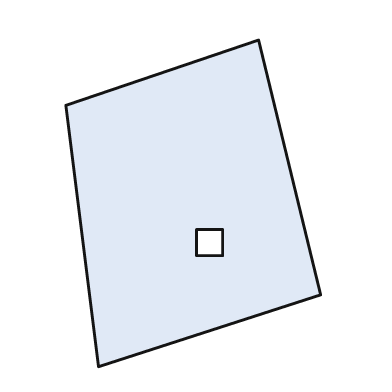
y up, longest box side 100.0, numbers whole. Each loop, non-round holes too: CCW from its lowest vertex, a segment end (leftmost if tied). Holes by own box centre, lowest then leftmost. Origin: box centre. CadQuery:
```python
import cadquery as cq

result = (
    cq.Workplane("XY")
    .moveTo(-29.0, -50.0)
    .lineTo(39.0, -28.0)
    .lineTo(20.0, 50.0)
    .lineTo(-39.0, 30.0)
    .close()
    .moveTo(1.0, -16.0)
    .lineTo(9.0, -16.0)
    .lineTo(9.0, -8.0)
    .lineTo(1.0, -8.0)
    .close()
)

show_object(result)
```